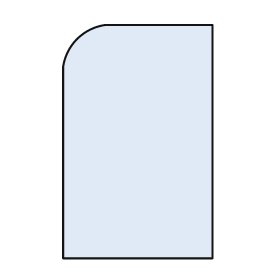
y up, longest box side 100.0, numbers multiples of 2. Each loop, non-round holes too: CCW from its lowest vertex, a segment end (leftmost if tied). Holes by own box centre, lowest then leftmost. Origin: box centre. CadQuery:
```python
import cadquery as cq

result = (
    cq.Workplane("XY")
    .moveTo(-32.0, -50.0)
    .lineTo(32.0, -50.0)
    .lineTo(32.0, 50.0)
    .lineTo(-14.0, 50.0)
    .threePointArc((-26.0, 44.0), (-32.0, 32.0))
    .close()
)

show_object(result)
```